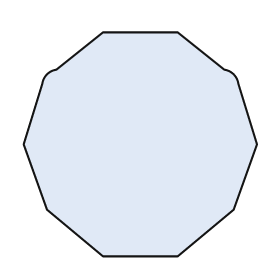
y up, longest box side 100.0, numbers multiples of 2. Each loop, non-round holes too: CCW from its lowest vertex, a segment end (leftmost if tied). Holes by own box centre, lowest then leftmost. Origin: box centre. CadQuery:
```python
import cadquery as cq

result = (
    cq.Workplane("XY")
    .moveTo(-16.0, -48.0)
    .lineTo(16.0, -48.0)
    .lineTo(40.0, -28.0)
    .lineTo(50.0, 0.0)
    .lineTo(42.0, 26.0)
    .threePointArc((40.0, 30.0), (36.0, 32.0))
    .lineTo(16.0, 48.0)
    .lineTo(-16.0, 48.0)
    .lineTo(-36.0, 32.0)
    .threePointArc((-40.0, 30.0), (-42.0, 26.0))
    .lineTo(-50.0, 0.0)
    .lineTo(-40.0, -28.0)
    .close()
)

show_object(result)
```